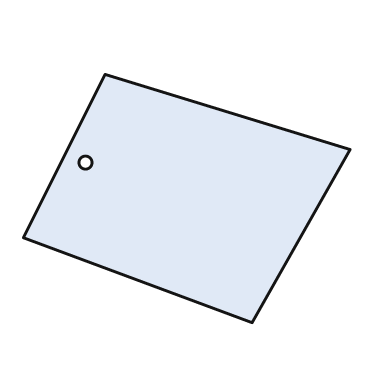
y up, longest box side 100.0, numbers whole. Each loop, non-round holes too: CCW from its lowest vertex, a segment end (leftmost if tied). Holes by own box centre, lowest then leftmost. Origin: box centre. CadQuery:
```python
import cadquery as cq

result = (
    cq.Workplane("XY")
    .moveTo(20.0, -38.0)
    .lineTo(50.0, 15.0)
    .lineTo(-25.0, 38.0)
    .lineTo(-50.0, -12.0)
    .close()
    .moveTo(-31.0, 11.0)
    .circle(2.0)
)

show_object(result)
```